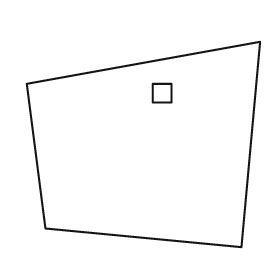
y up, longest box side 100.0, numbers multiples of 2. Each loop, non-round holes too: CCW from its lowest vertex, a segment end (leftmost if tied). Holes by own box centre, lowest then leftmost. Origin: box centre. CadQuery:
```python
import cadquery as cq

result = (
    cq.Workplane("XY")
    .moveTo(42.0, -44.0)
    .lineTo(50.0, 44.0)
    .lineTo(-50.0, 26.0)
    .lineTo(-42.0, -36.0)
    .close()
    .moveTo(4.0, 18.0)
    .lineTo(12.0, 18.0)
    .lineTo(12.0, 26.0)
    .lineTo(4.0, 26.0)
    .close()
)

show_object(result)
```